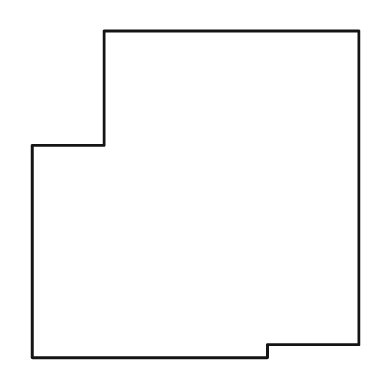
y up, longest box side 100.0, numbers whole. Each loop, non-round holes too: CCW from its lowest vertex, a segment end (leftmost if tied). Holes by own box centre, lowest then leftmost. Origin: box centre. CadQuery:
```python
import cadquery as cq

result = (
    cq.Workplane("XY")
    .moveTo(-50.0, -50.0)
    .lineTo(22.0, -50.0)
    .lineTo(22.0, -46.0)
    .lineTo(50.0, -46.0)
    .lineTo(50.0, 50.0)
    .lineTo(-28.0, 50.0)
    .lineTo(-28.0, 15.0)
    .lineTo(-50.0, 15.0)
    .close()
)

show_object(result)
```